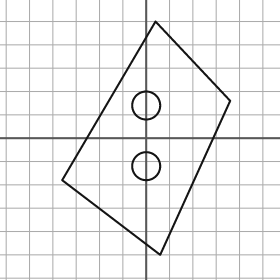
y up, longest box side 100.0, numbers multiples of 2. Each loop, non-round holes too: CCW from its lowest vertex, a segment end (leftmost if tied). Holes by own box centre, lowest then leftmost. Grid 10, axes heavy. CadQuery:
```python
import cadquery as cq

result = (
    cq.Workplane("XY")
    .moveTo(6.0, -50.0)
    .lineTo(36.0, 16.0)
    .lineTo(4.0, 50.0)
    .lineTo(-36.0, -18.0)
    .close()
    .moveTo(0.0, -12.0)
    .circle(6.0)
    .moveTo(0.0, 14.0)
    .circle(6.0)
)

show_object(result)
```